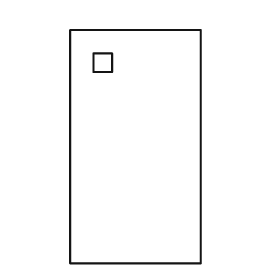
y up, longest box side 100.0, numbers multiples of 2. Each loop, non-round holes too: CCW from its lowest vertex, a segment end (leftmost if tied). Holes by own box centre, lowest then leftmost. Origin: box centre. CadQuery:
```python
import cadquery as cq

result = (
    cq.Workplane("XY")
    .moveTo(-28.0, -50.0)
    .lineTo(28.0, -50.0)
    .lineTo(28.0, 50.0)
    .lineTo(-28.0, 50.0)
    .close()
    .moveTo(-18.0, 32.0)
    .lineTo(-10.0, 32.0)
    .lineTo(-10.0, 40.0)
    .lineTo(-18.0, 40.0)
    .close()
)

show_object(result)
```